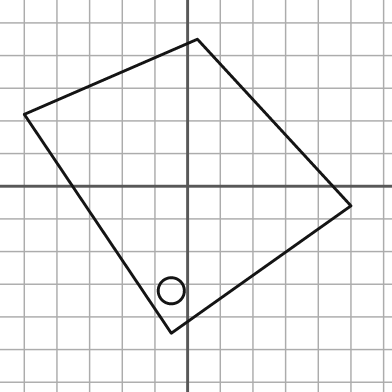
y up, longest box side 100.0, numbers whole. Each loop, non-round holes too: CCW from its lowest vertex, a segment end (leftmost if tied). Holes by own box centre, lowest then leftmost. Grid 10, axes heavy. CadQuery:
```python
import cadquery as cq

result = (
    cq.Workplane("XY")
    .moveTo(-5.0, -45.0)
    .lineTo(50.0, -6.0)
    .lineTo(3.0, 45.0)
    .lineTo(-50.0, 22.0)
    .close()
    .moveTo(-5.0, -32.0)
    .circle(4.0)
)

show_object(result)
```